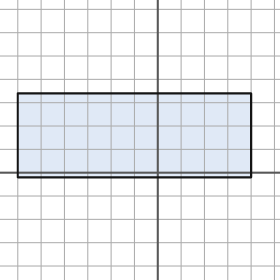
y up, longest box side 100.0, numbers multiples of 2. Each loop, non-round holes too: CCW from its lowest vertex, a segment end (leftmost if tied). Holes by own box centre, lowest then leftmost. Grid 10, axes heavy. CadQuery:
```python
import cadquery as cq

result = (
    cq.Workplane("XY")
    .moveTo(-60.0, -2.0)
    .lineTo(40.0, -2.0)
    .lineTo(40.0, 34.0)
    .lineTo(-60.0, 34.0)
    .close()
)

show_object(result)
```